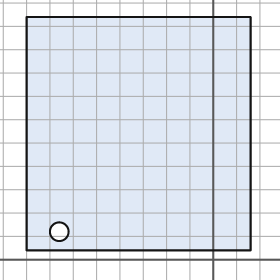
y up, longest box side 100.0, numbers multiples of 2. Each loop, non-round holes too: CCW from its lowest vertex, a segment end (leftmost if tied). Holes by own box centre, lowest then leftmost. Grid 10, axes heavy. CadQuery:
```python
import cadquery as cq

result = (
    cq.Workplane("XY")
    .moveTo(-80.0, 4.0)
    .lineTo(16.0, 4.0)
    .lineTo(16.0, 104.0)
    .lineTo(-80.0, 104.0)
    .close()
    .moveTo(-66.0, 12.0)
    .circle(4.0)
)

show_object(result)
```